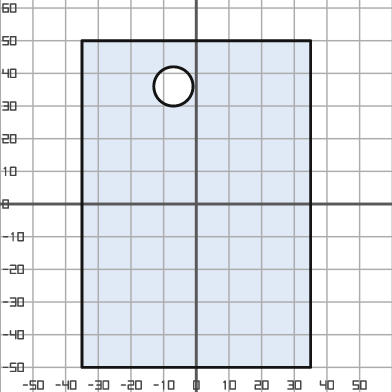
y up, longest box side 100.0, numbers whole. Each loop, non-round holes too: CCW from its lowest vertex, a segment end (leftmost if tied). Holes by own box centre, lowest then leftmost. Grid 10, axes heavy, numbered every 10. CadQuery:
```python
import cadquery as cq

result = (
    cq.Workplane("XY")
    .moveTo(-35.0, -50.0)
    .lineTo(35.0, -50.0)
    .lineTo(35.0, 50.0)
    .lineTo(-35.0, 50.0)
    .close()
    .moveTo(-7.0, 36.0)
    .circle(6.0)
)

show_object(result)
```